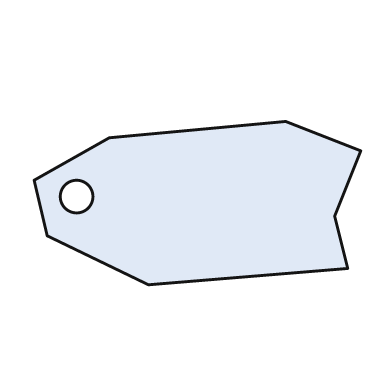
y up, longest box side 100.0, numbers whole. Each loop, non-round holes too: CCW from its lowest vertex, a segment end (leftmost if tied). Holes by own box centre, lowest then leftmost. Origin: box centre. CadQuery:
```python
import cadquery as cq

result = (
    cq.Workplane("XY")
    .moveTo(-15.0, -25.0)
    .lineTo(46.0, -20.0)
    .lineTo(42.0, -4.0)
    .lineTo(50.0, 16.0)
    .lineTo(27.0, 25.0)
    .lineTo(-27.0, 20.0)
    .lineTo(-50.0, 7.0)
    .lineTo(-46.0, -10.0)
    .close()
    .moveTo(-37.0, 2.0)
    .circle(5.0)
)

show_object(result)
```